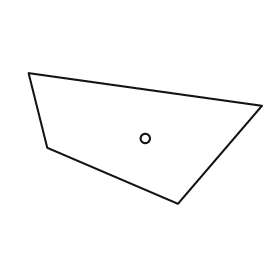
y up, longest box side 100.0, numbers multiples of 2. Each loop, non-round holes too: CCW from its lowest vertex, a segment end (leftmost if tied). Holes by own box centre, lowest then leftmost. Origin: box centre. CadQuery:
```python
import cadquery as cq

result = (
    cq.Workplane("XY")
    .moveTo(14.0, -28.0)
    .lineTo(50.0, 14.0)
    .lineTo(-50.0, 28.0)
    .lineTo(-42.0, -4.0)
    .close()
    .moveTo(0.0, 0.0)
    .circle(2.0)
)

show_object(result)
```